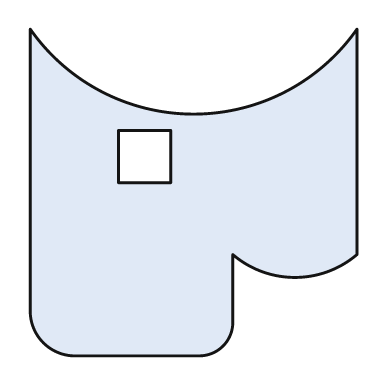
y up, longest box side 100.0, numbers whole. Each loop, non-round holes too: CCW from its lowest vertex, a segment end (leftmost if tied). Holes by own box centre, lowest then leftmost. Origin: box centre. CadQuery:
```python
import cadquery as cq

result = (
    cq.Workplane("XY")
    .moveTo(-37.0, -50.0)
    .lineTo(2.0, -50.0)
    .threePointArc((9.0, -47.0), (12.0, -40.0))
    .lineTo(12.0, -19.0)
    .threePointArc((31.0, -26.0), (50.0, -19.0))
    .lineTo(50.0, 50.0)
    .threePointArc((0.0, 24.0), (-50.0, 50.0))
    .lineTo(-50.0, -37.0)
    .threePointArc((-46.0, -46.0), (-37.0, -50.0))
    .close()
    .moveTo(-23.0, 3.0)
    .lineTo(-7.0, 3.0)
    .lineTo(-7.0, 19.0)
    .lineTo(-23.0, 19.0)
    .close()
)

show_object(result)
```